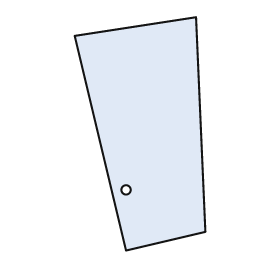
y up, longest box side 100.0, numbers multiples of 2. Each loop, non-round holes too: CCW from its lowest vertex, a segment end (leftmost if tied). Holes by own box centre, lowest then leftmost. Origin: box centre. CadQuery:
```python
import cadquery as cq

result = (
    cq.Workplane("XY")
    .moveTo(-6.0, -50.0)
    .lineTo(28.0, -42.0)
    .lineTo(24.0, 50.0)
    .lineTo(-28.0, 42.0)
    .close()
    .moveTo(-6.0, -24.0)
    .circle(2.0)
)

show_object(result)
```